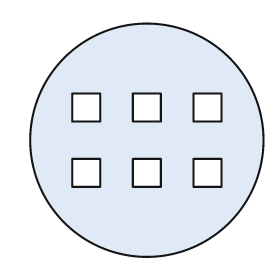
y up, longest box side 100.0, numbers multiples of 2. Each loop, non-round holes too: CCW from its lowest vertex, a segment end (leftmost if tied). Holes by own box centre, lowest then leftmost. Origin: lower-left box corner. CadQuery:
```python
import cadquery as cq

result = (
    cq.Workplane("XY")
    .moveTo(50.0, 50.0)
    .circle(50.0)
    .moveTo(18.0, 30.0)
    .lineTo(30.0, 30.0)
    .lineTo(30.0, 42.0)
    .lineTo(18.0, 42.0)
    .close()
    .moveTo(44.0, 30.0)
    .lineTo(56.0, 30.0)
    .lineTo(56.0, 42.0)
    .lineTo(44.0, 42.0)
    .close()
    .moveTo(70.0, 30.0)
    .lineTo(82.0, 30.0)
    .lineTo(82.0, 42.0)
    .lineTo(70.0, 42.0)
    .close()
    .moveTo(18.0, 58.0)
    .lineTo(30.0, 58.0)
    .lineTo(30.0, 70.0)
    .lineTo(18.0, 70.0)
    .close()
    .moveTo(44.0, 58.0)
    .lineTo(56.0, 58.0)
    .lineTo(56.0, 70.0)
    .lineTo(44.0, 70.0)
    .close()
    .moveTo(70.0, 58.0)
    .lineTo(82.0, 58.0)
    .lineTo(82.0, 70.0)
    .lineTo(70.0, 70.0)
    .close()
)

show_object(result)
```